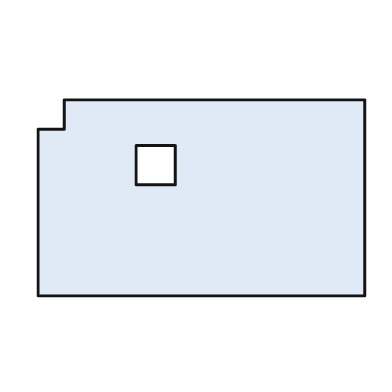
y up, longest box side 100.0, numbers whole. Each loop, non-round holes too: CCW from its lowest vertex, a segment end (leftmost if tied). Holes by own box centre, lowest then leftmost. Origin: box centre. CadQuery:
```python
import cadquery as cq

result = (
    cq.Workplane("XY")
    .moveTo(-50.0, -30.0)
    .lineTo(50.0, -30.0)
    .lineTo(50.0, 30.0)
    .lineTo(-42.0, 30.0)
    .lineTo(-42.0, 21.0)
    .lineTo(-50.0, 21.0)
    .close()
    .moveTo(-20.0, 4.0)
    .lineTo(-8.0, 4.0)
    .lineTo(-8.0, 16.0)
    .lineTo(-20.0, 16.0)
    .close()
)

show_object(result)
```